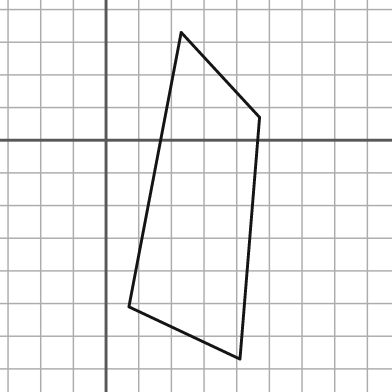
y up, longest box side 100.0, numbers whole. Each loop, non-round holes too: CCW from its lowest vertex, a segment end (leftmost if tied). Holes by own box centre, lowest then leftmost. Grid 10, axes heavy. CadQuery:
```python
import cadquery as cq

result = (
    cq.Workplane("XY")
    .moveTo(41.0, -67.0)
    .lineTo(47.0, 7.0)
    .lineTo(23.0, 33.0)
    .lineTo(7.0, -51.0)
    .close()
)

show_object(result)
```